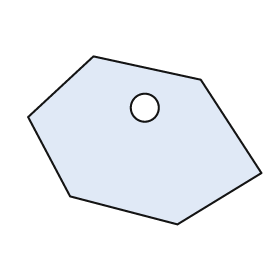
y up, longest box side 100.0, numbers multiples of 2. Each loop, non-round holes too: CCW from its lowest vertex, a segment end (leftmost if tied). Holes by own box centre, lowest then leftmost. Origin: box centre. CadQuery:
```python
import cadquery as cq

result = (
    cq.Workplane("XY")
    .moveTo(14.0, -36.0)
    .lineTo(50.0, -14.0)
    .lineTo(24.0, 26.0)
    .lineTo(-22.0, 36.0)
    .lineTo(-50.0, 10.0)
    .lineTo(-32.0, -24.0)
    .close()
    .moveTo(0.0, 14.0)
    .circle(6.0)
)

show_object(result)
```